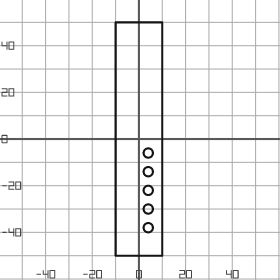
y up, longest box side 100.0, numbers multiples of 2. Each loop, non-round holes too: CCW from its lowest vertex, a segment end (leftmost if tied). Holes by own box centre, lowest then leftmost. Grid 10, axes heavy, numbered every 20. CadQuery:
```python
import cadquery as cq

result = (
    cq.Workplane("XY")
    .moveTo(-10.0, -50.0)
    .lineTo(10.0, -50.0)
    .lineTo(10.0, 50.0)
    .lineTo(-10.0, 50.0)
    .close()
    .moveTo(4.0, -38.0)
    .circle(2.0)
    .moveTo(4.0, -30.0)
    .circle(2.0)
    .moveTo(4.0, -22.0)
    .circle(2.0)
    .moveTo(4.0, -14.0)
    .circle(2.0)
    .moveTo(4.0, -6.0)
    .circle(2.0)
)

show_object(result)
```